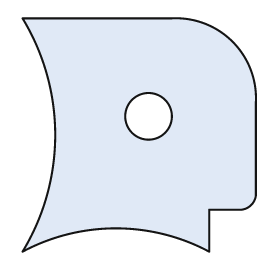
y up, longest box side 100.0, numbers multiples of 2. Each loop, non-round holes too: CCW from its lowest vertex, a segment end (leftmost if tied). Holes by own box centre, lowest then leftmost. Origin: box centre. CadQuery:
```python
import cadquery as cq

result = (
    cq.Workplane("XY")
    .moveTo(-50.0, -50.0)
    .threePointArc((-10.0, -40.0), (30.0, -50.0))
    .lineTo(30.0, -32.0)
    .lineTo(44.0, -32.0)
    .threePointArc((48.0, -30.0), (50.0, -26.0))
    .lineTo(50.0, 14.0)
    .threePointArc((40.0, 40.0), (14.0, 50.0))
    .lineTo(-50.0, 50.0)
    .threePointArc((-36.0, 0.0), (-50.0, -50.0))
    .close()
    .moveTo(4.0, 8.0)
    .circle(10.0)
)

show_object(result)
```